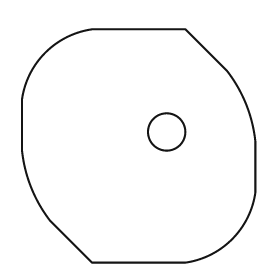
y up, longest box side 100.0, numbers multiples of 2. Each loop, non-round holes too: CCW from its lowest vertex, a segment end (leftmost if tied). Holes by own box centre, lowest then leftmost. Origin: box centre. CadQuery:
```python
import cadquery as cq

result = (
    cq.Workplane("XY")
    .moveTo(-20.0, -50.0)
    .lineTo(20.0, -50.0)
    .threePointArc((40.0, -40.0), (50.0, -20.0))
    .lineTo(50.0, 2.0)
    .threePointArc((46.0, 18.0), (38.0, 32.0))
    .lineTo(20.0, 50.0)
    .lineTo(-20.0, 50.0)
    .threePointArc((-40.0, 40.0), (-50.0, 20.0))
    .lineTo(-50.0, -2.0)
    .threePointArc((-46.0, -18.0), (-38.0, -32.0))
    .close()
    .moveTo(12.0, 6.0)
    .circle(8.0)
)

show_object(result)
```